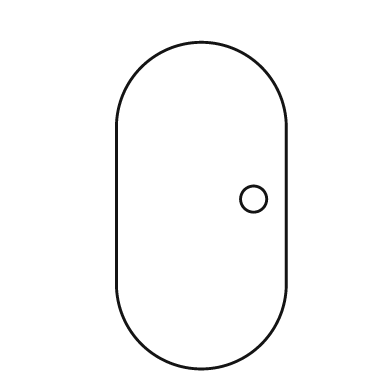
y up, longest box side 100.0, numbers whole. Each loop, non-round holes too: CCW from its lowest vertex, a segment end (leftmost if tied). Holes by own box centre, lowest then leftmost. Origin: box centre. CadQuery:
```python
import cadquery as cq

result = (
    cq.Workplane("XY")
    .moveTo(-26.0, -24.0)
    .threePointArc((0.0, -50.0), (26.0, -24.0))
    .lineTo(26.0, 24.0)
    .threePointArc((0.0, 50.0), (-26.0, 24.0))
    .close()
    .moveTo(16.0, 2.0)
    .circle(4.0)
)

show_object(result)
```